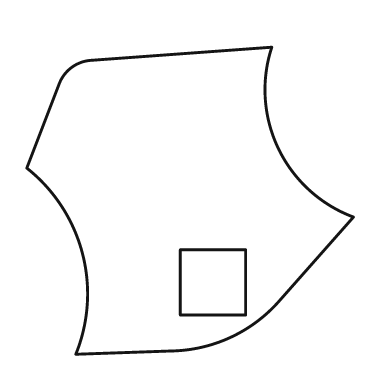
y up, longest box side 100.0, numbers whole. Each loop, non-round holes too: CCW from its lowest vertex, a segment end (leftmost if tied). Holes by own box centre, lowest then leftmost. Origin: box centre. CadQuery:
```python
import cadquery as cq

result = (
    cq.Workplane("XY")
    .moveTo(-35.0, -47.0)
    .lineTo(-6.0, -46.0)
    .threePointArc((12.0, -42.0), (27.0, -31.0))
    .lineTo(50.0, -5.0)
    .threePointArc((27.0, 16.0), (25.0, 47.0))
    .lineTo(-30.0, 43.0)
    .threePointArc((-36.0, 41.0), (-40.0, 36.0))
    .lineTo(-50.0, 10.0)
    .threePointArc((-33.0, -16.0), (-35.0, -47.0))
    .close()
    .moveTo(-3.0, -35.0)
    .lineTo(17.0, -35.0)
    .lineTo(17.0, -15.0)
    .lineTo(-3.0, -15.0)
    .close()
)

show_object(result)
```